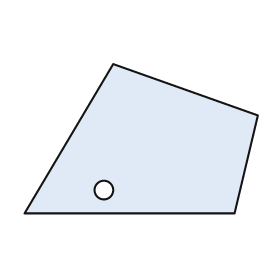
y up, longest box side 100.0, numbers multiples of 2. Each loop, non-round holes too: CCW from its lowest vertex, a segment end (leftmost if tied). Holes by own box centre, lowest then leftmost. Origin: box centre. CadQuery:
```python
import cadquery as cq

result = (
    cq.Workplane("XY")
    .moveTo(-50.0, -32.0)
    .lineTo(40.0, -32.0)
    .lineTo(50.0, 10.0)
    .lineTo(-12.0, 32.0)
    .close()
    .moveTo(-16.0, -22.0)
    .circle(4.0)
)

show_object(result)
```